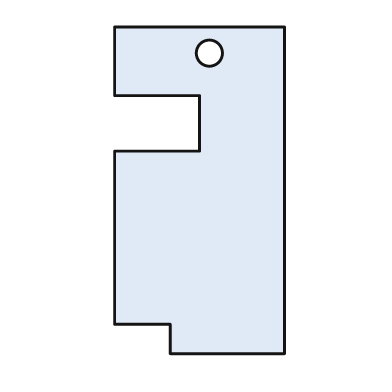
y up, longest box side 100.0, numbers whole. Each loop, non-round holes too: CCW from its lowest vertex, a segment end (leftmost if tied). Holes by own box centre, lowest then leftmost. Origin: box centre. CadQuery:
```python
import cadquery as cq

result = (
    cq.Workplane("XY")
    .moveTo(-9.0, -50.0)
    .lineTo(26.0, -50.0)
    .lineTo(26.0, 50.0)
    .lineTo(-26.0, 50.0)
    .lineTo(-26.0, 29.0)
    .lineTo(0.0, 29.0)
    .lineTo(0.0, 12.0)
    .lineTo(-26.0, 12.0)
    .lineTo(-26.0, -41.0)
    .lineTo(-9.0, -41.0)
    .close()
    .moveTo(3.0, 42.0)
    .circle(4.0)
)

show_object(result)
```